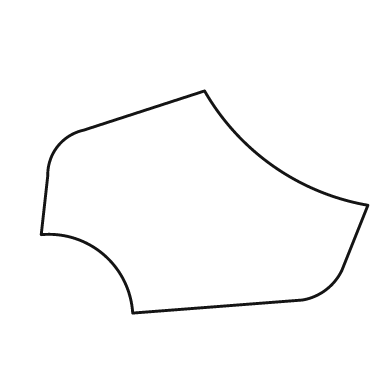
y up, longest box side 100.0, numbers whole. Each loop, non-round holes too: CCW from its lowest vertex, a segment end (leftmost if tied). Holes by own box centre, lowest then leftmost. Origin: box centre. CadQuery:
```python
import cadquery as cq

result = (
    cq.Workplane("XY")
    .moveTo(-22.0, -34.0)
    .lineTo(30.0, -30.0)
    .threePointArc((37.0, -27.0), (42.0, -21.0))
    .lineTo(50.0, -1.0)
    .threePointArc((21.0, 11.0), (0.0, 34.0))
    .lineTo(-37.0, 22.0)
    .threePointArc((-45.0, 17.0), (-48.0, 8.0))
    .lineTo(-50.0, -10.0)
    .threePointArc((-31.0, -16.0), (-22.0, -34.0))
    .close()
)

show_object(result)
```